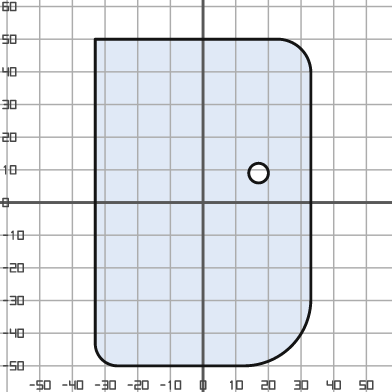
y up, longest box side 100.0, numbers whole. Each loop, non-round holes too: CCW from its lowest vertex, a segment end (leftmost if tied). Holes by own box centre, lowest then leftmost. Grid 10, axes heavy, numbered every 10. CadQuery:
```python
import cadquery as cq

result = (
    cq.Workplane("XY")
    .moveTo(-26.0, -50.0)
    .lineTo(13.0, -50.0)
    .threePointArc((27.0, -44.0), (33.0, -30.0))
    .lineTo(33.0, 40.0)
    .threePointArc((30.0, 47.0), (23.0, 50.0))
    .lineTo(-33.0, 50.0)
    .lineTo(-33.0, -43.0)
    .threePointArc((-31.0, -48.0), (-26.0, -50.0))
    .close()
    .moveTo(17.0, 9.0)
    .circle(3.0)
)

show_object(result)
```